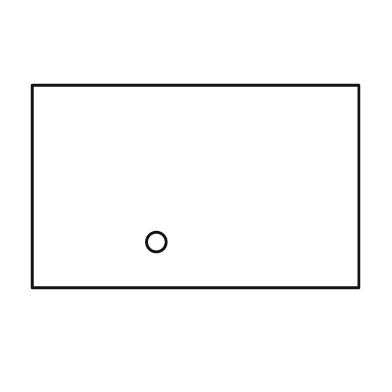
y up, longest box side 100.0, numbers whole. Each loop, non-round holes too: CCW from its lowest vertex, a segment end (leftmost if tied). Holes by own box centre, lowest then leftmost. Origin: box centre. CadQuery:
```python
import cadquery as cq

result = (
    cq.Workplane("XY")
    .moveTo(-50.0, -31.0)
    .lineTo(50.0, -31.0)
    .lineTo(50.0, 31.0)
    .lineTo(-50.0, 31.0)
    .close()
    .moveTo(-12.0, -17.0)
    .circle(3.0)
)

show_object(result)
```